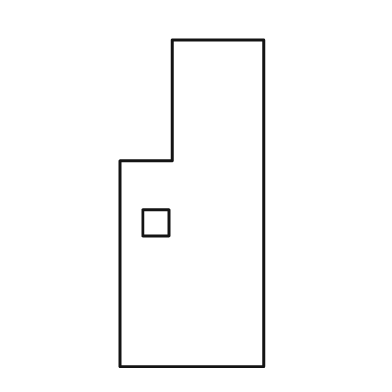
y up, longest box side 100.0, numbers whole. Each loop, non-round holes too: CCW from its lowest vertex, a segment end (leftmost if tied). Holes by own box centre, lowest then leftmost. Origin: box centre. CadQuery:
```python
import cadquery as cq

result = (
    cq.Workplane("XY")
    .moveTo(-22.0, -50.0)
    .lineTo(22.0, -50.0)
    .lineTo(22.0, 50.0)
    .lineTo(-6.0, 50.0)
    .lineTo(-6.0, 13.0)
    .lineTo(-22.0, 13.0)
    .close()
    .moveTo(-15.0, -10.0)
    .lineTo(-7.0, -10.0)
    .lineTo(-7.0, -2.0)
    .lineTo(-15.0, -2.0)
    .close()
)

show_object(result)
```